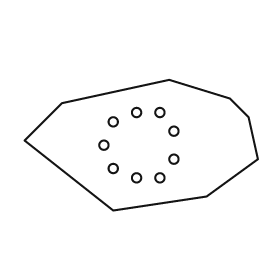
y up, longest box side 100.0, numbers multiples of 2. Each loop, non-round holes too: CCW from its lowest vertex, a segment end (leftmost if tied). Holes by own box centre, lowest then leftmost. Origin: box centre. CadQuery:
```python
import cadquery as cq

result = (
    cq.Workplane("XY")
    .moveTo(-12.0, -28.0)
    .lineTo(28.0, -22.0)
    .lineTo(50.0, -6.0)
    .lineTo(46.0, 12.0)
    .lineTo(38.0, 20.0)
    .lineTo(12.0, 28.0)
    .lineTo(-34.0, 18.0)
    .lineTo(-50.0, 2.0)
    .close()
    .moveTo(-2.0, -14.0)
    .circle(2.0)
    .moveTo(8.0, -14.0)
    .circle(2.0)
    .moveTo(-12.0, -10.0)
    .circle(2.0)
    .moveTo(14.0, -6.0)
    .circle(2.0)
    .moveTo(-16.0, 0.0)
    .circle(2.0)
    .moveTo(14.0, 6.0)
    .circle(2.0)
    .moveTo(-12.0, 10.0)
    .circle(2.0)
    .moveTo(-2.0, 14.0)
    .circle(2.0)
    .moveTo(8.0, 14.0)
    .circle(2.0)
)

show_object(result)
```